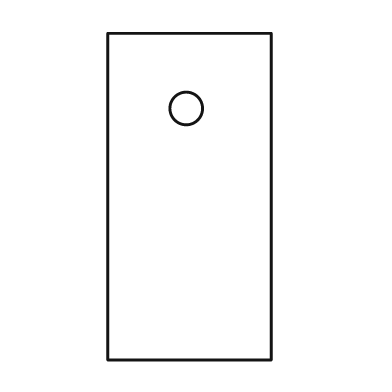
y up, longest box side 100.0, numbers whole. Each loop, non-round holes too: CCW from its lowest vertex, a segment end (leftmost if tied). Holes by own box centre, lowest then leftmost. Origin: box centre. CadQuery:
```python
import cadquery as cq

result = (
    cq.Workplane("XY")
    .moveTo(-25.0, -50.0)
    .lineTo(25.0, -50.0)
    .lineTo(25.0, 50.0)
    .lineTo(-25.0, 50.0)
    .close()
    .moveTo(-1.0, 27.0)
    .circle(5.0)
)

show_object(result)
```